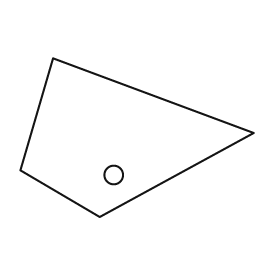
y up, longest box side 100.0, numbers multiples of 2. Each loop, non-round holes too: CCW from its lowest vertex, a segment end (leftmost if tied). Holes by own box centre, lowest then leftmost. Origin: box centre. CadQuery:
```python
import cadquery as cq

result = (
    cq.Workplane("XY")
    .moveTo(-16.0, -34.0)
    .lineTo(50.0, 2.0)
    .lineTo(-36.0, 34.0)
    .lineTo(-50.0, -14.0)
    .close()
    .moveTo(-10.0, -16.0)
    .circle(4.0)
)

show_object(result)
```